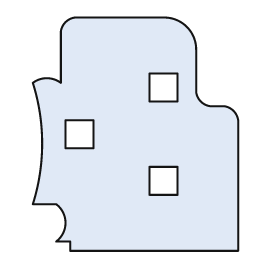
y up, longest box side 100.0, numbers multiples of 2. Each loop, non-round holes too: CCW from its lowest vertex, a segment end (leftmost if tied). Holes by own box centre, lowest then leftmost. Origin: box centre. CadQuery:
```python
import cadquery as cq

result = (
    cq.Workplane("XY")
    .moveTo(-28.0, -50.0)
    .lineTo(44.0, -50.0)
    .lineTo(44.0, 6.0)
    .threePointArc((42.0, 10.0), (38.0, 12.0))
    .lineTo(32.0, 12.0)
    .threePointArc((28.0, 14.0), (26.0, 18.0))
    .lineTo(26.0, 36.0)
    .threePointArc((22.0, 46.0), (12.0, 50.0))
    .lineTo(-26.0, 50.0)
    .threePointArc((-30.0, 48.0), (-32.0, 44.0))
    .lineTo(-32.0, 22.0)
    .threePointArc((-38.0, 24.0), (-44.0, 22.0))
    .threePointArc((-40.0, -4.0), (-44.0, -30.0))
    .lineTo(-34.0, -30.0)
    .threePointArc((-30.0, -38.0), (-34.0, -46.0))
    .lineTo(-28.0, -46.0)
    .close()
    .moveTo(6.0, -26.0)
    .lineTo(18.0, -26.0)
    .lineTo(18.0, -14.0)
    .lineTo(6.0, -14.0)
    .close()
    .moveTo(-30.0, -6.0)
    .lineTo(-18.0, -6.0)
    .lineTo(-18.0, 6.0)
    .lineTo(-30.0, 6.0)
    .close()
    .moveTo(6.0, 14.0)
    .lineTo(18.0, 14.0)
    .lineTo(18.0, 26.0)
    .lineTo(6.0, 26.0)
    .close()
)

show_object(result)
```